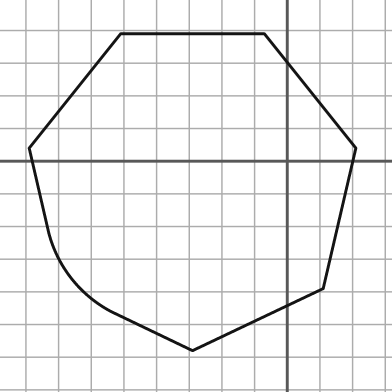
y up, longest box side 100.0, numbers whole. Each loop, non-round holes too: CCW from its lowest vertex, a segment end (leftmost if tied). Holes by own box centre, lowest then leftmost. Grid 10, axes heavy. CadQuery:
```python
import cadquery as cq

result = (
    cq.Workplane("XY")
    .moveTo(-29.0, -58.0)
    .lineTo(11.0, -39.0)
    .lineTo(21.0, 4.0)
    .lineTo(-7.0, 39.0)
    .lineTo(-51.0, 39.0)
    .lineTo(-79.0, 4.0)
    .lineTo(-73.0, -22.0)
    .threePointArc((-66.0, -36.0), (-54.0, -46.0))
    .close()
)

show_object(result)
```